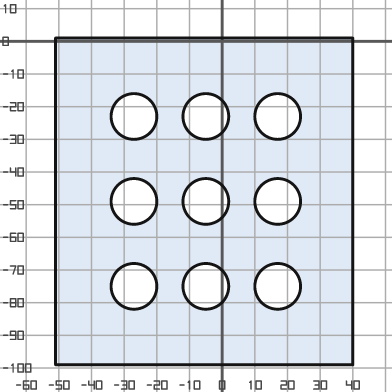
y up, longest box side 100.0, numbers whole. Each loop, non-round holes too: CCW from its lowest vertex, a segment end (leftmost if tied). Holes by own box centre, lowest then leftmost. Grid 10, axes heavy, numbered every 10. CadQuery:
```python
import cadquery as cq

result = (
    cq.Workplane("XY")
    .moveTo(-51.0, -99.0)
    .lineTo(40.0, -99.0)
    .lineTo(40.0, 1.0)
    .lineTo(-51.0, 1.0)
    .close()
    .moveTo(-27.0, -75.0)
    .circle(7.0)
    .moveTo(-5.0, -75.0)
    .circle(7.0)
    .moveTo(17.0, -75.0)
    .circle(7.0)
    .moveTo(-27.0, -49.0)
    .circle(7.0)
    .moveTo(-5.0, -49.0)
    .circle(7.0)
    .moveTo(17.0, -49.0)
    .circle(7.0)
    .moveTo(-27.0, -23.0)
    .circle(7.0)
    .moveTo(-5.0, -23.0)
    .circle(7.0)
    .moveTo(17.0, -23.0)
    .circle(7.0)
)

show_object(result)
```